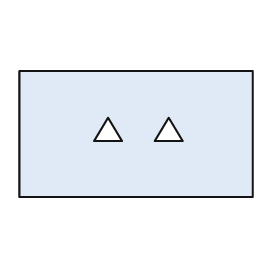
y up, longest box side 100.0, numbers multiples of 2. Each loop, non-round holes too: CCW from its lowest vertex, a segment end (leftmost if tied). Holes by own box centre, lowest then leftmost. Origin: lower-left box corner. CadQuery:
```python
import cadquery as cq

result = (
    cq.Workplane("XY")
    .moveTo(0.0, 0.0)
    .lineTo(100.0, 0.0)
    .lineTo(100.0, 54.0)
    .lineTo(0.0, 54.0)
    .close()
    .moveTo(32.0, 24.0)
    .lineTo(44.0, 24.0)
    .lineTo(38.0, 34.0)
    .close()
    .moveTo(58.0, 24.0)
    .lineTo(70.0, 24.0)
    .lineTo(64.0, 34.0)
    .close()
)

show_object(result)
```